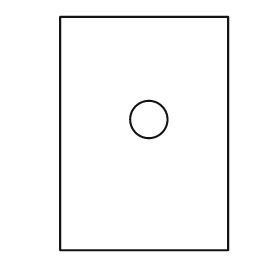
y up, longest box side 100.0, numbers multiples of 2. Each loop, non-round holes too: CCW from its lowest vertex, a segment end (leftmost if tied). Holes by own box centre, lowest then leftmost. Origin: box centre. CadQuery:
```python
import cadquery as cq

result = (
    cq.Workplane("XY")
    .moveTo(-36.0, -50.0)
    .lineTo(36.0, -50.0)
    .lineTo(36.0, 50.0)
    .lineTo(-36.0, 50.0)
    .close()
    .moveTo(2.0, 6.0)
    .circle(8.0)
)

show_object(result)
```